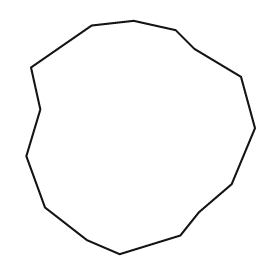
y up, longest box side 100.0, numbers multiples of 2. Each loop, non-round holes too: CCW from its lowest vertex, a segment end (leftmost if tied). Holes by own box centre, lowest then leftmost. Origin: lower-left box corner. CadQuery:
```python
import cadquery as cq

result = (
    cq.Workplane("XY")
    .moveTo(40.0, 0.0)
    .lineTo(66.0, 8.0)
    .lineTo(74.0, 18.0)
    .lineTo(88.0, 30.0)
    .lineTo(98.0, 54.0)
    .lineTo(92.0, 76.0)
    .lineTo(72.0, 88.0)
    .lineTo(64.0, 96.0)
    .lineTo(46.0, 100.0)
    .lineTo(28.0, 98.0)
    .lineTo(2.0, 80.0)
    .lineTo(6.0, 62.0)
    .lineTo(0.0, 42.0)
    .lineTo(8.0, 20.0)
    .lineTo(26.0, 6.0)
    .close()
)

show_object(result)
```